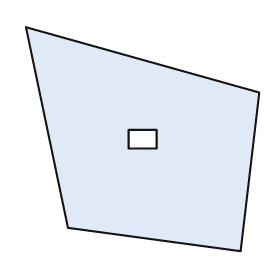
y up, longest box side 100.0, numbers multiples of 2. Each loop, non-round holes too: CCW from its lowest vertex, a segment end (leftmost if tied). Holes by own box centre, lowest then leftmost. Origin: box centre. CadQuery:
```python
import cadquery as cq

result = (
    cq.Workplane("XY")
    .moveTo(42.0, -48.0)
    .lineTo(50.0, 20.0)
    .lineTo(-50.0, 48.0)
    .lineTo(-32.0, -38.0)
    .close()
    .moveTo(-6.0, -4.0)
    .lineTo(6.0, -4.0)
    .lineTo(6.0, 4.0)
    .lineTo(-6.0, 4.0)
    .close()
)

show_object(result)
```